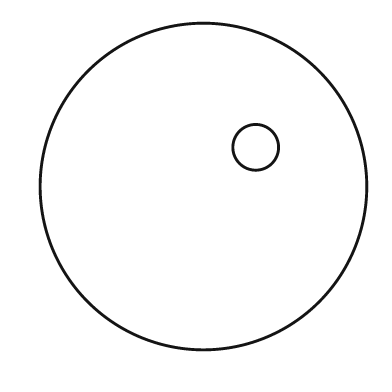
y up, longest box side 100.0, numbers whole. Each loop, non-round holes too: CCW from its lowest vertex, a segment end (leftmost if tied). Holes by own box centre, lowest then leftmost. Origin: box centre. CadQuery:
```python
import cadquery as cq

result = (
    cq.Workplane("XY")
    .moveTo(0.0, 0.0)
    .circle(50.0)
    .moveTo(16.0, 12.0)
    .circle(7.0)
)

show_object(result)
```